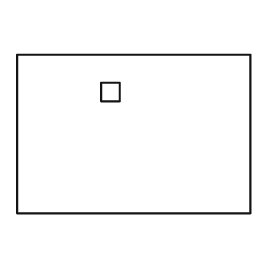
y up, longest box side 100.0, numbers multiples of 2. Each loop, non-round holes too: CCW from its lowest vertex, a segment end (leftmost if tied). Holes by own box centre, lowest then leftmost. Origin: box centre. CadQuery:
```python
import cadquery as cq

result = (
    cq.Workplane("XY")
    .moveTo(-50.0, -34.0)
    .lineTo(50.0, -34.0)
    .lineTo(50.0, 34.0)
    .lineTo(-50.0, 34.0)
    .close()
    .moveTo(-14.0, 14.0)
    .lineTo(-6.0, 14.0)
    .lineTo(-6.0, 22.0)
    .lineTo(-14.0, 22.0)
    .close()
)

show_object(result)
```